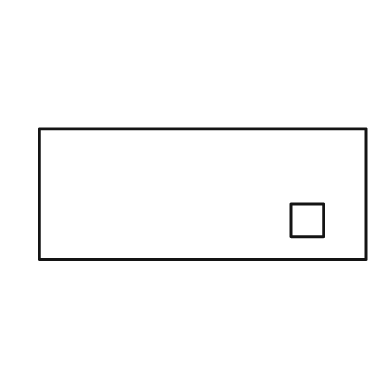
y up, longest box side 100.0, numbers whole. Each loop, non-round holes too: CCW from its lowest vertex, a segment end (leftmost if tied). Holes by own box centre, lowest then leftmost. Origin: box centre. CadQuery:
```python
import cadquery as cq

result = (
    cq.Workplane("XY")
    .moveTo(-50.0, -20.0)
    .lineTo(50.0, -20.0)
    .lineTo(50.0, 20.0)
    .lineTo(-50.0, 20.0)
    .close()
    .moveTo(27.0, -13.0)
    .lineTo(37.0, -13.0)
    .lineTo(37.0, -3.0)
    .lineTo(27.0, -3.0)
    .close()
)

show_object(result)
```